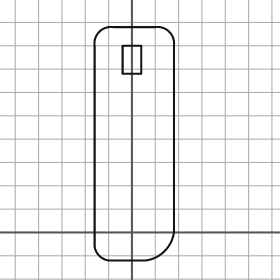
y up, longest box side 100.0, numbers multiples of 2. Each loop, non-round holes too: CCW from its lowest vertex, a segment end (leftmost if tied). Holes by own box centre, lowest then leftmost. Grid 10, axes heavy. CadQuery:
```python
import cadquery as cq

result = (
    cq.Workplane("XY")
    .moveTo(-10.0, -12.0)
    .lineTo(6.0, -12.0)
    .threePointArc((14.0, -8.0), (18.0, 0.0))
    .lineTo(18.0, 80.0)
    .threePointArc((16.0, 86.0), (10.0, 88.0))
    .lineTo(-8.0, 88.0)
    .threePointArc((-14.0, 86.0), (-16.0, 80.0))
    .lineTo(-16.0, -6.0)
    .threePointArc((-14.0, -10.0), (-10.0, -12.0))
    .close()
    .moveTo(-4.0, 68.0)
    .lineTo(4.0, 68.0)
    .lineTo(4.0, 80.0)
    .lineTo(-4.0, 80.0)
    .close()
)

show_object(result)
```